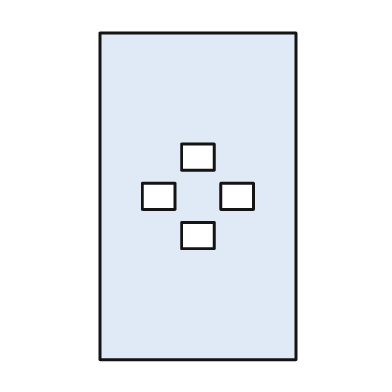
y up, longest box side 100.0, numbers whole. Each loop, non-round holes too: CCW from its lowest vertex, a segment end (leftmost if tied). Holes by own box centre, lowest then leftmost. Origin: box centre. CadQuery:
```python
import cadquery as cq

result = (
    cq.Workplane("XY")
    .moveTo(-30.0, -50.0)
    .lineTo(30.0, -50.0)
    .lineTo(30.0, 50.0)
    .lineTo(-30.0, 50.0)
    .close()
    .moveTo(-5.0, -16.0)
    .lineTo(5.0, -16.0)
    .lineTo(5.0, -8.0)
    .lineTo(-5.0, -8.0)
    .close()
    .moveTo(-17.0, -4.0)
    .lineTo(-7.0, -4.0)
    .lineTo(-7.0, 4.0)
    .lineTo(-17.0, 4.0)
    .close()
    .moveTo(7.0, -4.0)
    .lineTo(17.0, -4.0)
    .lineTo(17.0, 4.0)
    .lineTo(7.0, 4.0)
    .close()
    .moveTo(-5.0, 8.0)
    .lineTo(5.0, 8.0)
    .lineTo(5.0, 16.0)
    .lineTo(-5.0, 16.0)
    .close()
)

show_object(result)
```